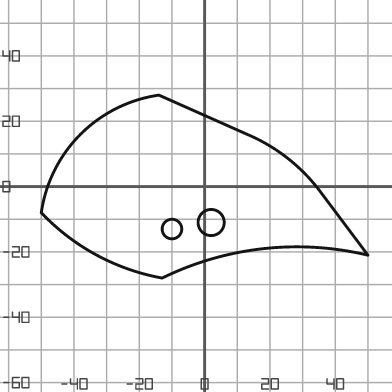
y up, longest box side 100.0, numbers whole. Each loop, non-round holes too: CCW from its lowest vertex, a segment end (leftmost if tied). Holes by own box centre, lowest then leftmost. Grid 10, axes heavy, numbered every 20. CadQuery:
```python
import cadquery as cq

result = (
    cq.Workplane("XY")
    .moveTo(-13.0, -28.0)
    .threePointArc((18.0, -19.0), (50.0, -21.0))
    .lineTo(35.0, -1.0)
    .threePointArc((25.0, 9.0), (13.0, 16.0))
    .lineTo(-14.0, 28.0)
    .threePointArc((-38.0, 16.0), (-50.0, -8.0))
    .threePointArc((-33.0, -21.0), (-13.0, -28.0))
    .close()
    .moveTo(-10.0, -13.0)
    .circle(3.0)
    .moveTo(2.0, -11.0)
    .circle(4.0)
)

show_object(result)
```